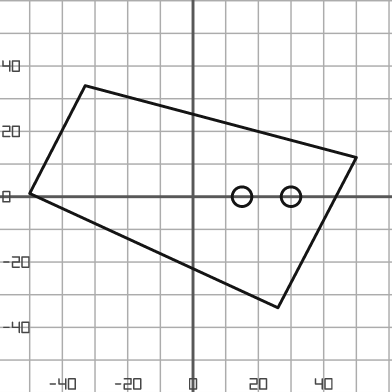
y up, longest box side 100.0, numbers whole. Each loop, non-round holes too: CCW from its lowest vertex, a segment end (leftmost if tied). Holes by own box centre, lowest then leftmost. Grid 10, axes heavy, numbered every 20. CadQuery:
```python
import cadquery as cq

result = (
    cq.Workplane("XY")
    .moveTo(26.0, -34.0)
    .lineTo(50.0, 12.0)
    .lineTo(-33.0, 34.0)
    .lineTo(-50.0, 1.0)
    .close()
    .moveTo(15.0, 0.0)
    .circle(3.0)
    .moveTo(30.0, 0.0)
    .circle(3.0)
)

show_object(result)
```